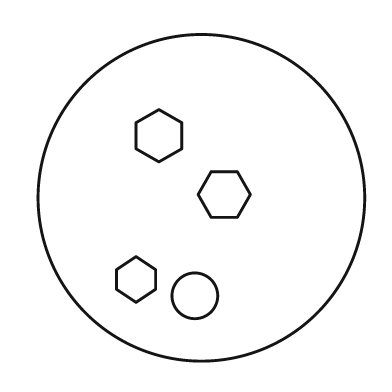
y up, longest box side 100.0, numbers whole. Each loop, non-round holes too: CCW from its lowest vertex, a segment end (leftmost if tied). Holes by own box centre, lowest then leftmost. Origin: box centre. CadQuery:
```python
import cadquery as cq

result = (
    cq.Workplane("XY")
    .moveTo(0.0, 0.0)
    .circle(50.0)
    .moveTo(-2.0, -30.0)
    .circle(7.0)
    .moveTo(-20.0, -32.0)
    .lineTo(-14.0, -28.0)
    .lineTo(-14.0, -22.0)
    .lineTo(-20.0, -18.0)
    .lineTo(-26.0, -22.0)
    .lineTo(-26.0, -28.0)
    .close()
    .moveTo(3.0, -6.0)
    .lineTo(11.0, -6.0)
    .lineTo(15.0, 1.0)
    .lineTo(11.0, 8.0)
    .lineTo(3.0, 8.0)
    .lineTo(-1.0, 1.0)
    .close()
    .moveTo(-13.0, 11.0)
    .lineTo(-6.0, 15.0)
    .lineTo(-6.0, 23.0)
    .lineTo(-13.0, 27.0)
    .lineTo(-20.0, 23.0)
    .lineTo(-20.0, 15.0)
    .close()
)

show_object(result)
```